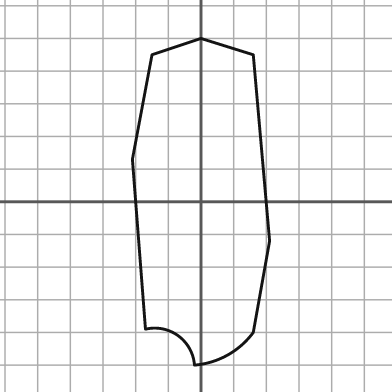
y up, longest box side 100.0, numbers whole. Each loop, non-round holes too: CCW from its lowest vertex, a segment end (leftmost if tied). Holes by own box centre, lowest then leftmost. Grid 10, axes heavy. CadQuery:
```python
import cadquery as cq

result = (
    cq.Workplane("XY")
    .moveTo(-2.0, -50.0)
    .threePointArc((8.0, -47.0), (16.0, -40.0))
    .lineTo(21.0, -12.0)
    .lineTo(16.0, 45.0)
    .lineTo(0.0, 50.0)
    .lineTo(-15.0, 45.0)
    .lineTo(-21.0, 13.0)
    .lineTo(-17.0, -39.0)
    .threePointArc((-7.0, -41.0), (-2.0, -50.0))
    .close()
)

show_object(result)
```